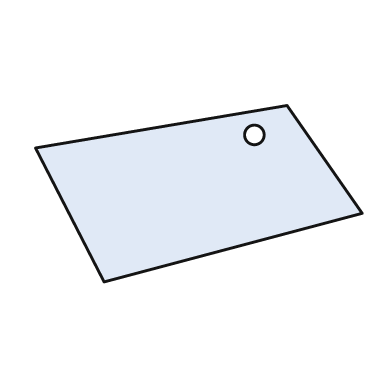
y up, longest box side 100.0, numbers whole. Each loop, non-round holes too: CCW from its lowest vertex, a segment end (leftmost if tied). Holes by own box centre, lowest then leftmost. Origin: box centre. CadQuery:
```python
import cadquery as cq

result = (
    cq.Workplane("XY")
    .moveTo(-29.0, -27.0)
    .lineTo(50.0, -6.0)
    .lineTo(27.0, 27.0)
    .lineTo(-50.0, 14.0)
    .close()
    .moveTo(17.0, 18.0)
    .circle(3.0)
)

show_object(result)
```